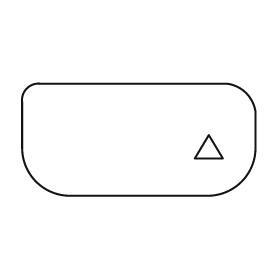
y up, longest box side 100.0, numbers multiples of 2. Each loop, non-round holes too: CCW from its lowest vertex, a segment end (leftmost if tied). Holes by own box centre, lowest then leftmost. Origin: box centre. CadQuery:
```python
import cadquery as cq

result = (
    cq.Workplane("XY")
    .moveTo(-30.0, -24.0)
    .lineTo(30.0, -24.0)
    .threePointArc((44.0, -18.0), (50.0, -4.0))
    .lineTo(50.0, 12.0)
    .threePointArc((46.0, 20.0), (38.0, 24.0))
    .lineTo(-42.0, 24.0)
    .threePointArc((-48.0, 22.0), (-50.0, 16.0))
    .lineTo(-50.0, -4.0)
    .threePointArc((-44.0, -18.0), (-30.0, -24.0))
    .close()
    .moveTo(24.0, -8.0)
    .lineTo(36.0, -8.0)
    .lineTo(30.0, 2.0)
    .close()
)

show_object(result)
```